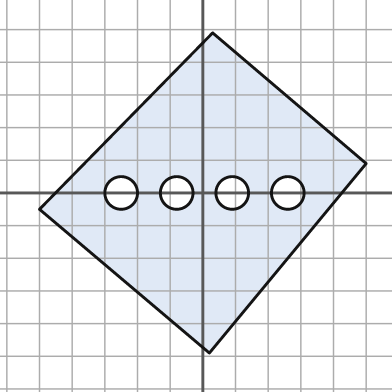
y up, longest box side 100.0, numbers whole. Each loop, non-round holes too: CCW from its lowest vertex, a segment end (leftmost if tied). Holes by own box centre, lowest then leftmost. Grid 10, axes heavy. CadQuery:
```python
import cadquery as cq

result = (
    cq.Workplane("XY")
    .moveTo(2.0, -49.0)
    .lineTo(50.0, 9.0)
    .lineTo(3.0, 49.0)
    .lineTo(-50.0, -5.0)
    .close()
    .moveTo(-25.0, 0.0)
    .circle(5.0)
    .moveTo(-8.0, 0.0)
    .circle(5.0)
    .moveTo(9.0, 0.0)
    .circle(5.0)
    .moveTo(26.0, 0.0)
    .circle(5.0)
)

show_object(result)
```